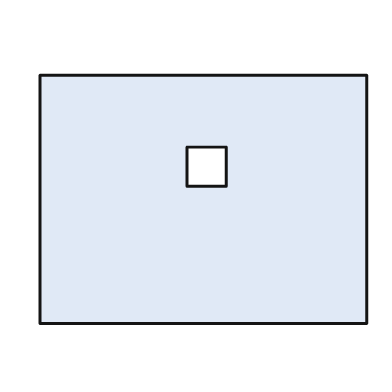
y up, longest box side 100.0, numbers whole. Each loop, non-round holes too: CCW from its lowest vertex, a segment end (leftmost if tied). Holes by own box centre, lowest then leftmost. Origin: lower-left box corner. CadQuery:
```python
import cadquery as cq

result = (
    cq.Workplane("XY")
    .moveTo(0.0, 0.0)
    .lineTo(100.0, 0.0)
    .lineTo(100.0, 76.0)
    .lineTo(0.0, 76.0)
    .close()
    .moveTo(45.0, 42.0)
    .lineTo(57.0, 42.0)
    .lineTo(57.0, 54.0)
    .lineTo(45.0, 54.0)
    .close()
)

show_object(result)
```